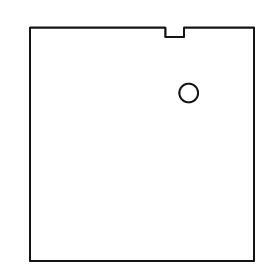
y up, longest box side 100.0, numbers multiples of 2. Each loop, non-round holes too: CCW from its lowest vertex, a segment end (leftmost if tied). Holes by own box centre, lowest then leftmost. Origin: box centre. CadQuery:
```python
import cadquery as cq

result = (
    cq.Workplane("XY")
    .moveTo(-48.0, -50.0)
    .lineTo(48.0, -50.0)
    .lineTo(48.0, 50.0)
    .lineTo(18.0, 50.0)
    .lineTo(18.0, 46.0)
    .lineTo(10.0, 46.0)
    .lineTo(10.0, 50.0)
    .lineTo(-48.0, 50.0)
    .close()
    .moveTo(20.0, 22.0)
    .circle(4.0)
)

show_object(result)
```